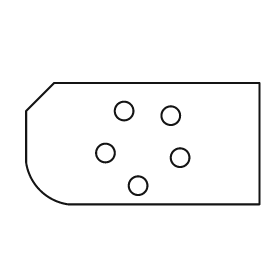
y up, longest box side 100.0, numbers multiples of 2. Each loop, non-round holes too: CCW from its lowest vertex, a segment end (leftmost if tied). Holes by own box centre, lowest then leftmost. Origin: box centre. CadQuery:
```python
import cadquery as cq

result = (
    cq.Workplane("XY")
    .moveTo(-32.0, -26.0)
    .lineTo(50.0, -26.0)
    .lineTo(50.0, 26.0)
    .lineTo(-38.0, 26.0)
    .lineTo(-50.0, 14.0)
    .lineTo(-50.0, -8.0)
    .threePointArc((-44.0, -20.0), (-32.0, -26.0))
    .close()
    .moveTo(-2.0, -18.0)
    .circle(4.0)
    .moveTo(16.0, -6.0)
    .circle(4.0)
    .moveTo(-16.0, -4.0)
    .circle(4.0)
    .moveTo(12.0, 12.0)
    .circle(4.0)
    .moveTo(-8.0, 14.0)
    .circle(4.0)
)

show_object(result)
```